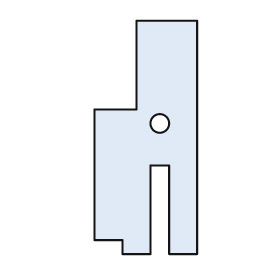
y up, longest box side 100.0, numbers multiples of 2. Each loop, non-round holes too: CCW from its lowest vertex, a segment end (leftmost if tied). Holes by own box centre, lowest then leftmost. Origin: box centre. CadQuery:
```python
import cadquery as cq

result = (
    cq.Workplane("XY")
    .moveTo(-10.0, -50.0)
    .lineTo(2.0, -50.0)
    .lineTo(2.0, -12.0)
    .lineTo(10.0, -12.0)
    .lineTo(10.0, -50.0)
    .lineTo(22.0, -50.0)
    .lineTo(22.0, 50.0)
    .lineTo(-4.0, 50.0)
    .lineTo(-4.0, 12.0)
    .lineTo(-22.0, 12.0)
    .lineTo(-22.0, -44.0)
    .lineTo(-10.0, -44.0)
    .close()
    .moveTo(6.0, 6.0)
    .circle(4.0)
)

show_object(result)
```